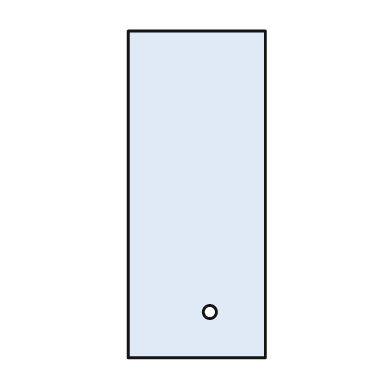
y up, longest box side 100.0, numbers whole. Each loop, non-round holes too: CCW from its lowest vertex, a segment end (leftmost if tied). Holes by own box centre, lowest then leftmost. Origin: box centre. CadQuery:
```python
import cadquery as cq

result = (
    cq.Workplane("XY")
    .moveTo(-21.0, -50.0)
    .lineTo(21.0, -50.0)
    .lineTo(21.0, 50.0)
    .lineTo(-21.0, 50.0)
    .close()
    .moveTo(4.0, -36.0)
    .circle(2.0)
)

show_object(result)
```